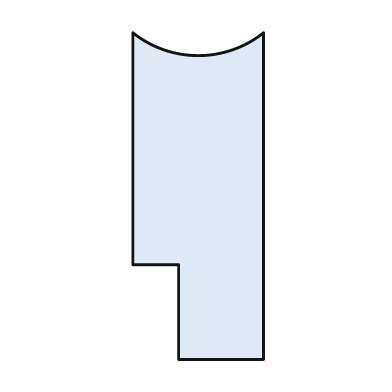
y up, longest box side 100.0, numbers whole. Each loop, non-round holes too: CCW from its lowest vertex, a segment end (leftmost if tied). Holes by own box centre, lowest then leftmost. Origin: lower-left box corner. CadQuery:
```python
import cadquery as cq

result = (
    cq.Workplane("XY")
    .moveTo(14.0, 0.0)
    .lineTo(40.0, 0.0)
    .lineTo(40.0, 100.0)
    .threePointArc((20.0, 93.0), (0.0, 100.0))
    .lineTo(0.0, 29.0)
    .lineTo(14.0, 29.0)
    .close()
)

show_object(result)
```